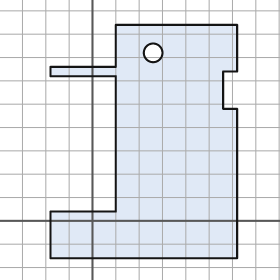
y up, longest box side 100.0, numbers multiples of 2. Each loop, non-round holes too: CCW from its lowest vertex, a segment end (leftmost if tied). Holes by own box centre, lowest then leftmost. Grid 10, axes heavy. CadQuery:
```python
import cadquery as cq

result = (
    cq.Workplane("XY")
    .moveTo(-18.0, -16.0)
    .lineTo(62.0, -16.0)
    .lineTo(62.0, 48.0)
    .lineTo(56.0, 48.0)
    .lineTo(56.0, 64.0)
    .lineTo(62.0, 64.0)
    .lineTo(62.0, 84.0)
    .lineTo(10.0, 84.0)
    .lineTo(10.0, 66.0)
    .lineTo(-18.0, 66.0)
    .lineTo(-18.0, 62.0)
    .lineTo(10.0, 62.0)
    .lineTo(10.0, 4.0)
    .lineTo(-18.0, 4.0)
    .close()
    .moveTo(26.0, 72.0)
    .circle(4.0)
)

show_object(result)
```